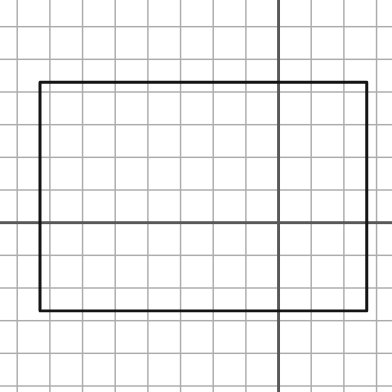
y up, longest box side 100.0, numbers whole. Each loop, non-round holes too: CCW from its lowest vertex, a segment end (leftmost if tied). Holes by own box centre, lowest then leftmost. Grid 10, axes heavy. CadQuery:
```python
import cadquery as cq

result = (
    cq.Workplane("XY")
    .moveTo(-73.0, -27.0)
    .lineTo(27.0, -27.0)
    .lineTo(27.0, 43.0)
    .lineTo(-73.0, 43.0)
    .close()
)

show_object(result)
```